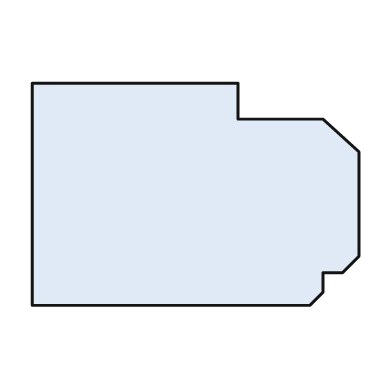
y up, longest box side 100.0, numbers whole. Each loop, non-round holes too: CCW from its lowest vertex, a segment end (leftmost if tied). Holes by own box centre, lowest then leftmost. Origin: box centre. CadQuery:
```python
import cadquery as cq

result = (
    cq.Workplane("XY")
    .moveTo(-50.0, -34.0)
    .lineTo(35.0, -34.0)
    .lineTo(39.0, -30.0)
    .lineTo(39.0, -24.0)
    .lineTo(45.0, -24.0)
    .lineTo(50.0, -19.0)
    .lineTo(50.0, 13.0)
    .lineTo(39.0, 23.0)
    .lineTo(13.0, 23.0)
    .lineTo(13.0, 34.0)
    .lineTo(-50.0, 34.0)
    .close()
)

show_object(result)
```